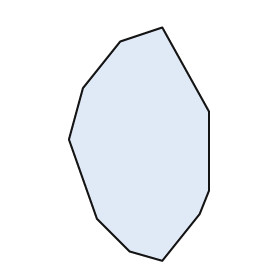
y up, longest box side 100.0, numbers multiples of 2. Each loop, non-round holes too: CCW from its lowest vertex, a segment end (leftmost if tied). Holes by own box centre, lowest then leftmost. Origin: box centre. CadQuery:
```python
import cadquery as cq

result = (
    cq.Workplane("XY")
    .moveTo(10.0, -50.0)
    .lineTo(26.0, -30.0)
    .lineTo(30.0, -20.0)
    .lineTo(30.0, 14.0)
    .lineTo(10.0, 50.0)
    .lineTo(-8.0, 44.0)
    .lineTo(-24.0, 24.0)
    .lineTo(-30.0, 2.0)
    .lineTo(-18.0, -32.0)
    .lineTo(-4.0, -46.0)
    .close()
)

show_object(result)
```